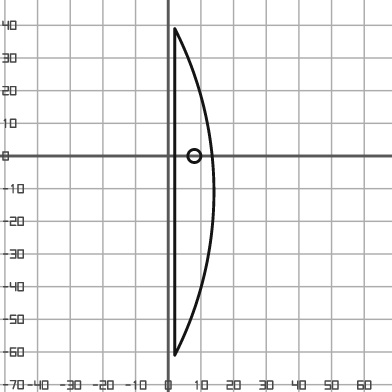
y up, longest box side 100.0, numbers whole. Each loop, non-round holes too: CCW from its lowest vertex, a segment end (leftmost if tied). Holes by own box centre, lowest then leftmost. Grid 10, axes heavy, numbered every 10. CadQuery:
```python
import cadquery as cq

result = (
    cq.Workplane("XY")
    .moveTo(2.0, -61.0)
    .threePointArc((14.0, -11.0), (2.0, 39.0))
    .close()
    .moveTo(8.0, 0.0)
    .circle(2.0)
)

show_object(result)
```